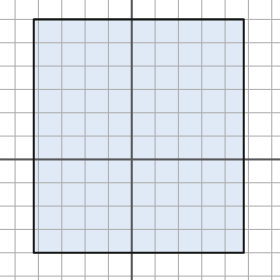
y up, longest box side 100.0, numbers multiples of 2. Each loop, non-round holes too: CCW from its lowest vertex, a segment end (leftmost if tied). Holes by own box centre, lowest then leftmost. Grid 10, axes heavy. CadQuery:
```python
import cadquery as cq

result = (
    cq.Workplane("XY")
    .moveTo(-42.0, -40.0)
    .lineTo(48.0, -40.0)
    .lineTo(48.0, 60.0)
    .lineTo(-42.0, 60.0)
    .close()
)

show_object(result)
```